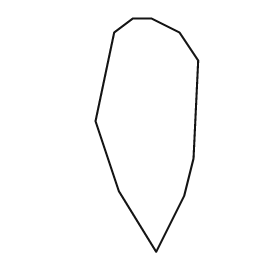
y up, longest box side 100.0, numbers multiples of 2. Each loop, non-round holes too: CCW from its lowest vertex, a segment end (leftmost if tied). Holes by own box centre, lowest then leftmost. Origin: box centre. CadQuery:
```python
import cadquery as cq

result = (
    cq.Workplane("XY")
    .moveTo(4.0, -50.0)
    .lineTo(16.0, -26.0)
    .lineTo(20.0, -10.0)
    .lineTo(22.0, 32.0)
    .lineTo(14.0, 44.0)
    .lineTo(2.0, 50.0)
    .lineTo(-6.0, 50.0)
    .lineTo(-14.0, 44.0)
    .lineTo(-22.0, 6.0)
    .lineTo(-12.0, -24.0)
    .close()
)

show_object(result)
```